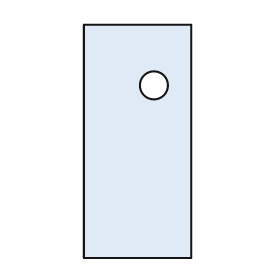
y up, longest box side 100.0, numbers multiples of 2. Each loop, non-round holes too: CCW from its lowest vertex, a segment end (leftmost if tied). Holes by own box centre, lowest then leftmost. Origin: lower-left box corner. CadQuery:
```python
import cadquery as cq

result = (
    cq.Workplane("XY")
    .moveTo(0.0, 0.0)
    .lineTo(46.0, 0.0)
    .lineTo(46.0, 100.0)
    .lineTo(0.0, 100.0)
    .close()
    .moveTo(30.0, 74.0)
    .circle(6.0)
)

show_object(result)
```